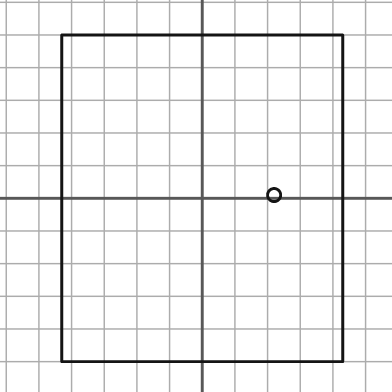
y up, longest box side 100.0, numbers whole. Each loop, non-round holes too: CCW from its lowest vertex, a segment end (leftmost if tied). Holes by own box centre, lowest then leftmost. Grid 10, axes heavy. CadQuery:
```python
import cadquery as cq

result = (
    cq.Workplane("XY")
    .moveTo(-43.0, -50.0)
    .lineTo(43.0, -50.0)
    .lineTo(43.0, 50.0)
    .lineTo(-43.0, 50.0)
    .close()
    .moveTo(22.0, 1.0)
    .circle(2.0)
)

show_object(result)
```